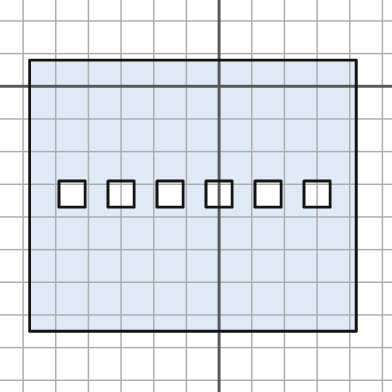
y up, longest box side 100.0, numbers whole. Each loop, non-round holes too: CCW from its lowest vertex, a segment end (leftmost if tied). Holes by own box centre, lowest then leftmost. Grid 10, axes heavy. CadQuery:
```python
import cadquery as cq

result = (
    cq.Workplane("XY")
    .moveTo(-58.0, -75.0)
    .lineTo(42.0, -75.0)
    .lineTo(42.0, 8.0)
    .lineTo(-58.0, 8.0)
    .close()
    .moveTo(-49.0, -37.0)
    .lineTo(-41.0, -37.0)
    .lineTo(-41.0, -29.0)
    .lineTo(-49.0, -29.0)
    .close()
    .moveTo(-34.0, -37.0)
    .lineTo(-26.0, -37.0)
    .lineTo(-26.0, -29.0)
    .lineTo(-34.0, -29.0)
    .close()
    .moveTo(-19.0, -37.0)
    .lineTo(-11.0, -37.0)
    .lineTo(-11.0, -29.0)
    .lineTo(-19.0, -29.0)
    .close()
    .moveTo(-4.0, -37.0)
    .lineTo(4.0, -37.0)
    .lineTo(4.0, -29.0)
    .lineTo(-4.0, -29.0)
    .close()
    .moveTo(11.0, -37.0)
    .lineTo(19.0, -37.0)
    .lineTo(19.0, -29.0)
    .lineTo(11.0, -29.0)
    .close()
    .moveTo(26.0, -37.0)
    .lineTo(34.0, -37.0)
    .lineTo(34.0, -29.0)
    .lineTo(26.0, -29.0)
    .close()
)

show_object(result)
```